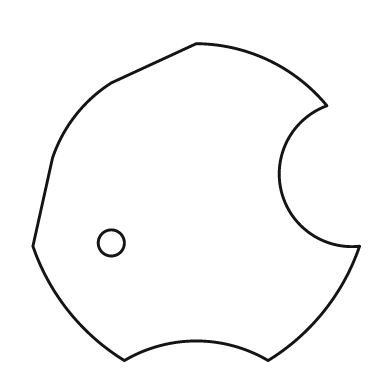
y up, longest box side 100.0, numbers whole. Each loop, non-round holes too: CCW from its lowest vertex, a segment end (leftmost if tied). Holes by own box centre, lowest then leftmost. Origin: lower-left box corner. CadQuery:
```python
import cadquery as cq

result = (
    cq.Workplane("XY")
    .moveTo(28.0, 0.0)
    .threePointArc((50.0, 6.0), (72.0, 0.0))
    .threePointArc((89.0, 15.0), (100.0, 35.0))
    .threePointArc((76.0, 52.0), (90.0, 78.0))
    .threePointArc((72.0, 92.0), (50.0, 97.0))
    .lineTo(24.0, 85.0)
    .threePointArc((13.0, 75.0), (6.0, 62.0))
    .lineTo(0.0, 35.0)
    .threePointArc((11.0, 15.0), (28.0, 0.0))
    .close()
    .moveTo(24.0, 36.0)
    .circle(4.0)
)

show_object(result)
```